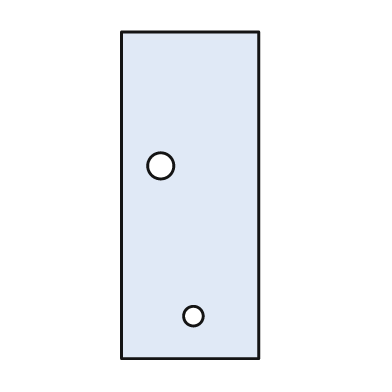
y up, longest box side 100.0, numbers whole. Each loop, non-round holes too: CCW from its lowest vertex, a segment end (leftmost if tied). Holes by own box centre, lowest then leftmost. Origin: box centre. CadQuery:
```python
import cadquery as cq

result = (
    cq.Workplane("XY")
    .moveTo(-21.0, -50.0)
    .lineTo(21.0, -50.0)
    .lineTo(21.0, 50.0)
    .lineTo(-21.0, 50.0)
    .close()
    .moveTo(1.0, -37.0)
    .circle(3.0)
    .moveTo(-9.0, 9.0)
    .circle(4.0)
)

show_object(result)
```